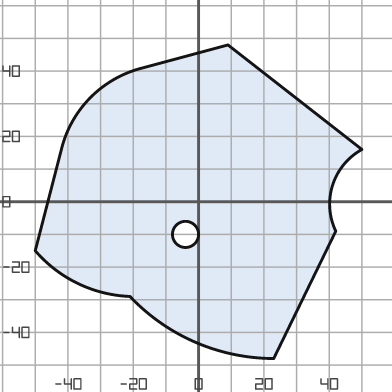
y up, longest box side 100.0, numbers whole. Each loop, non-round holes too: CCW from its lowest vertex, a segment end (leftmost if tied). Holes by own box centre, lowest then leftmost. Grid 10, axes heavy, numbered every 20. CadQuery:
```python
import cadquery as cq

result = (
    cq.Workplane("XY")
    .moveTo(23.0, -48.0)
    .lineTo(42.0, -9.0)
    .threePointArc((41.0, 5.0), (50.0, 16.0))
    .lineTo(9.0, 48.0)
    .lineTo(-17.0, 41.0)
    .threePointArc((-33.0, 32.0), (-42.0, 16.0))
    .lineTo(-50.0, -15.0)
    .threePointArc((-37.0, -25.0), (-21.0, -29.0))
    .threePointArc((-1.0, -43.0), (23.0, -48.0))
    .close()
    .moveTo(-4.0, -10.0)
    .circle(4.0)
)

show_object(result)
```